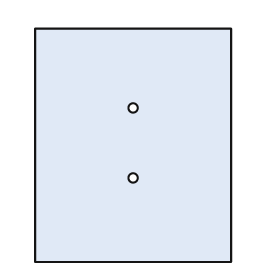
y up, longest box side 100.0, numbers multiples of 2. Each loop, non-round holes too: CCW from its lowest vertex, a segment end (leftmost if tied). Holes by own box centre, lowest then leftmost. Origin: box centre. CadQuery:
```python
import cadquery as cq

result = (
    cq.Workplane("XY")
    .moveTo(-42.0, -50.0)
    .lineTo(42.0, -50.0)
    .lineTo(42.0, 50.0)
    .lineTo(-42.0, 50.0)
    .close()
    .moveTo(0.0, -14.0)
    .circle(2.0)
    .moveTo(0.0, 16.0)
    .circle(2.0)
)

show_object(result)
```